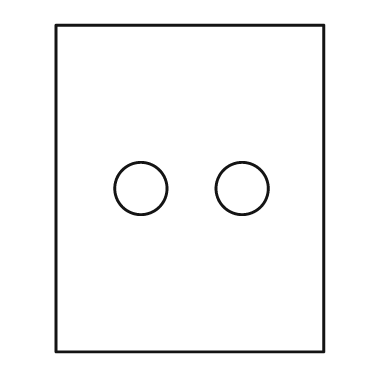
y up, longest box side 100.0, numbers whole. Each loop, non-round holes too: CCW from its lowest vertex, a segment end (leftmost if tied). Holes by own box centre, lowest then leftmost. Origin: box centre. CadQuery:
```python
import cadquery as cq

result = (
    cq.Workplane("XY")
    .moveTo(-41.0, -50.0)
    .lineTo(41.0, -50.0)
    .lineTo(41.0, 50.0)
    .lineTo(-41.0, 50.0)
    .close()
    .moveTo(-15.0, 0.0)
    .circle(8.0)
    .moveTo(16.0, 0.0)
    .circle(8.0)
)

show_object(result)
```